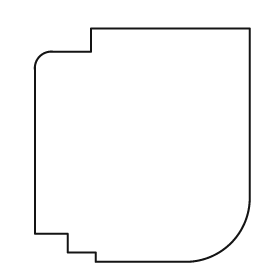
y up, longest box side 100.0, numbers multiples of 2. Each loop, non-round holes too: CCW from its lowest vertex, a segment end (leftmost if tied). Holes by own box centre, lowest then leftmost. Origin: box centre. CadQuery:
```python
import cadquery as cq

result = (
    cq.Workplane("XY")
    .moveTo(-20.0, -50.0)
    .lineTo(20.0, -50.0)
    .threePointArc((38.0, -42.0), (46.0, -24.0))
    .lineTo(46.0, 50.0)
    .lineTo(-22.0, 50.0)
    .lineTo(-22.0, 40.0)
    .lineTo(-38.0, 40.0)
    .threePointArc((-44.0, 38.0), (-46.0, 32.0))
    .lineTo(-46.0, -38.0)
    .lineTo(-32.0, -38.0)
    .lineTo(-32.0, -46.0)
    .lineTo(-20.0, -46.0)
    .close()
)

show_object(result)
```